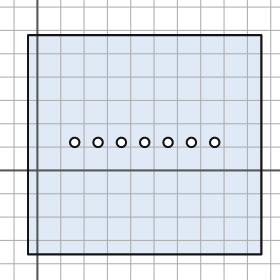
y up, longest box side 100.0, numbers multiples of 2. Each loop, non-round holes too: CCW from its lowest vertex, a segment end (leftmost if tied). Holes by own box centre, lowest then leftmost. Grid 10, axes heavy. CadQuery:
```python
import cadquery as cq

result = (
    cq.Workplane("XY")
    .moveTo(-4.0, -36.0)
    .lineTo(96.0, -36.0)
    .lineTo(96.0, 58.0)
    .lineTo(-4.0, 58.0)
    .close()
    .moveTo(16.0, 12.0)
    .circle(2.0)
    .moveTo(26.0, 12.0)
    .circle(2.0)
    .moveTo(36.0, 12.0)
    .circle(2.0)
    .moveTo(46.0, 12.0)
    .circle(2.0)
    .moveTo(56.0, 12.0)
    .circle(2.0)
    .moveTo(66.0, 12.0)
    .circle(2.0)
    .moveTo(76.0, 12.0)
    .circle(2.0)
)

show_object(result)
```